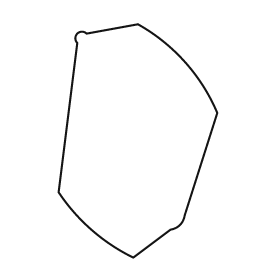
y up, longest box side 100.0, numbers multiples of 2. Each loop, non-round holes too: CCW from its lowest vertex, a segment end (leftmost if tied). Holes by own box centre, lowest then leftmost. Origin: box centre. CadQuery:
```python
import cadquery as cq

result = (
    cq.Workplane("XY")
    .moveTo(-2.0, -50.0)
    .lineTo(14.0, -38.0)
    .threePointArc((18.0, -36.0), (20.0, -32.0))
    .lineTo(34.0, 12.0)
    .threePointArc((20.0, 34.0), (0.0, 50.0))
    .lineTo(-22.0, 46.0)
    .threePointArc((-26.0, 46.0), (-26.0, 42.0))
    .lineTo(-34.0, -22.0)
    .threePointArc((-20.0, -38.0), (-2.0, -50.0))
    .close()
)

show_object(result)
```